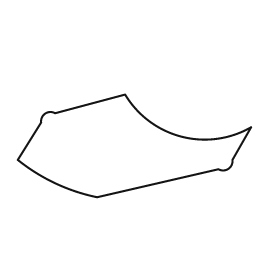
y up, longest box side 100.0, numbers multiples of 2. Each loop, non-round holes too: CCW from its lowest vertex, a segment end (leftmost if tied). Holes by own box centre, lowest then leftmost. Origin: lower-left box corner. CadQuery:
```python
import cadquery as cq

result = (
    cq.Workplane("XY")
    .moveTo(34.0, 0.0)
    .lineTo(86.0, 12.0)
    .threePointArc((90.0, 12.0), (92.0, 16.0))
    .lineTo(100.0, 30.0)
    .threePointArc((70.0, 26.0), (46.0, 44.0))
    .lineTo(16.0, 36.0)
    .threePointArc((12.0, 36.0), (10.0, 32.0))
    .lineTo(0.0, 16.0)
    .threePointArc((16.0, 6.0), (34.0, 0.0))
    .close()
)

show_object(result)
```